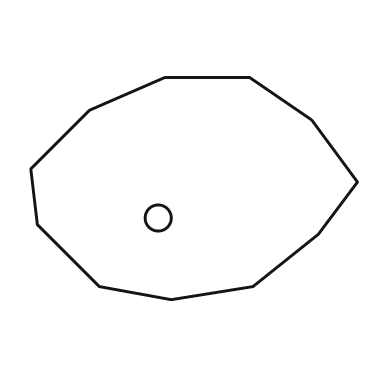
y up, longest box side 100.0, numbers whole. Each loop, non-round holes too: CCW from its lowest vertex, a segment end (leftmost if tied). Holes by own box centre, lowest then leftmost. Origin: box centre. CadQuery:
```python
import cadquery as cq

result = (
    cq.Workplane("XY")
    .moveTo(-7.0, -34.0)
    .lineTo(18.0, -30.0)
    .lineTo(38.0, -14.0)
    .lineTo(50.0, 2.0)
    .lineTo(36.0, 21.0)
    .lineTo(17.0, 34.0)
    .lineTo(-9.0, 34.0)
    .lineTo(-32.0, 24.0)
    .lineTo(-50.0, 6.0)
    .lineTo(-48.0, -11.0)
    .lineTo(-29.0, -30.0)
    .close()
    .moveTo(-11.0, -9.0)
    .circle(4.0)
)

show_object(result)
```